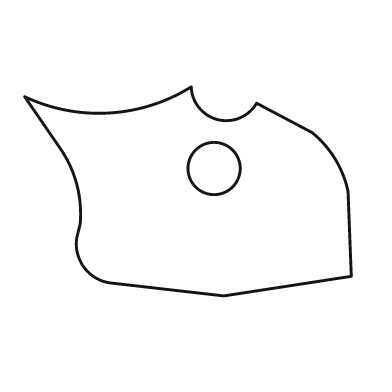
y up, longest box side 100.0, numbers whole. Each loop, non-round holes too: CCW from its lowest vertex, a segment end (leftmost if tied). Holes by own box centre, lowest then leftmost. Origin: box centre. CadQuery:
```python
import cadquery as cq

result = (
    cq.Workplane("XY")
    .moveTo(11.0, -32.0)
    .lineTo(50.0, -26.0)
    .lineTo(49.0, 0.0)
    .threePointArc((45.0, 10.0), (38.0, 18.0))
    .lineTo(21.0, 27.0)
    .threePointArc((9.0, 22.0), (1.0, 32.0))
    .threePointArc((-24.0, 24.0), (-50.0, 29.0))
    .lineTo(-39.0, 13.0)
    .threePointArc((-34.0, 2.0), (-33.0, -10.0))
    .lineTo(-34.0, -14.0)
    .threePointArc((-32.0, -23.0), (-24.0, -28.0))
    .close()
    .moveTo(8.0, 7.0)
    .circle(8.0)
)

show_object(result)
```